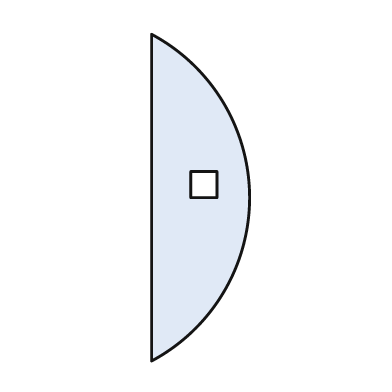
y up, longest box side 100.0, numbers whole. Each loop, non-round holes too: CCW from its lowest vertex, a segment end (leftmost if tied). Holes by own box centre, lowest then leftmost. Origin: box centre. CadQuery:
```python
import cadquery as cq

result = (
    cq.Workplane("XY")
    .moveTo(-15.0, -50.0)
    .threePointArc((15.0, 0.0), (-15.0, 50.0))
    .close()
    .moveTo(-3.0, 0.0)
    .lineTo(5.0, 0.0)
    .lineTo(5.0, 8.0)
    .lineTo(-3.0, 8.0)
    .close()
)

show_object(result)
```